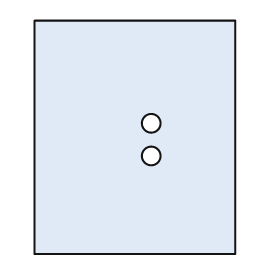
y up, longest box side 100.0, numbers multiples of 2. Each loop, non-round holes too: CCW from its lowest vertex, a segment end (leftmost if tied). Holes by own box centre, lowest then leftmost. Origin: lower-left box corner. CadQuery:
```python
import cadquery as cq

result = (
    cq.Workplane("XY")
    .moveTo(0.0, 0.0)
    .lineTo(86.0, 0.0)
    .lineTo(86.0, 100.0)
    .lineTo(0.0, 100.0)
    .close()
    .moveTo(50.0, 42.0)
    .circle(4.0)
    .moveTo(50.0, 56.0)
    .circle(4.0)
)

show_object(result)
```